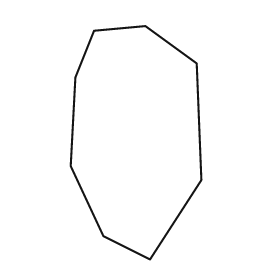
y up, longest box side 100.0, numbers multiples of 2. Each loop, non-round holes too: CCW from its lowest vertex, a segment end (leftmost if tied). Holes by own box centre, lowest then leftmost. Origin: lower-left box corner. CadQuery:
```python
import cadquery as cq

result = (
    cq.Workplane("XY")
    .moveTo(34.0, 0.0)
    .lineTo(56.0, 34.0)
    .lineTo(54.0, 84.0)
    .lineTo(32.0, 100.0)
    .lineTo(10.0, 98.0)
    .lineTo(2.0, 78.0)
    .lineTo(0.0, 40.0)
    .lineTo(14.0, 10.0)
    .close()
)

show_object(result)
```